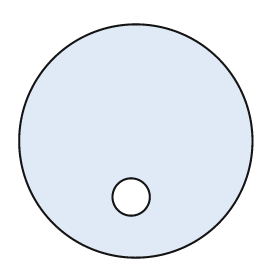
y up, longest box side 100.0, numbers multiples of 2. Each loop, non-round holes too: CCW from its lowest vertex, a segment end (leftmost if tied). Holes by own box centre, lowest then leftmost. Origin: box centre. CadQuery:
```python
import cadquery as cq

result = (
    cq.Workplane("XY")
    .moveTo(0.0, 0.0)
    .circle(50.0)
    .moveTo(-2.0, -24.0)
    .circle(8.0)
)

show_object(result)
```